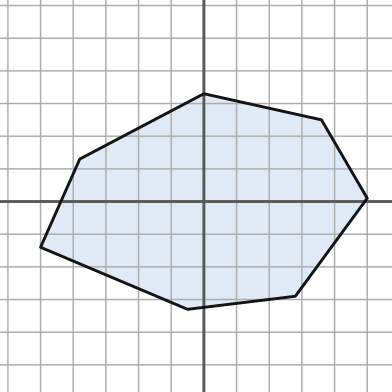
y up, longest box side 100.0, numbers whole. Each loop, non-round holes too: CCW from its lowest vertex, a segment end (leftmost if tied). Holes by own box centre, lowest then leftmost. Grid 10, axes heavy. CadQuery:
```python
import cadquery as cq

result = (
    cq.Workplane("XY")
    .moveTo(-5.0, -33.0)
    .lineTo(28.0, -29.0)
    .lineTo(50.0, 1.0)
    .lineTo(36.0, 25.0)
    .lineTo(0.0, 33.0)
    .lineTo(-38.0, 13.0)
    .lineTo(-50.0, -14.0)
    .close()
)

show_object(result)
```